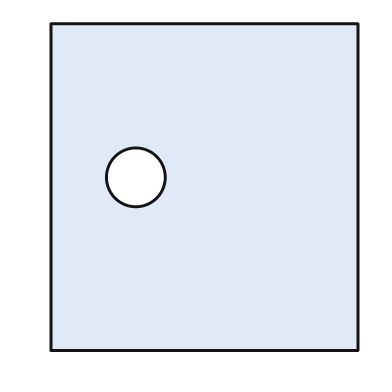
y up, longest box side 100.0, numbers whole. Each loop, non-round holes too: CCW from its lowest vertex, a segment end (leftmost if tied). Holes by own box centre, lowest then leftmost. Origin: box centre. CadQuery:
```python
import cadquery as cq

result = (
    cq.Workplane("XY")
    .moveTo(-47.0, -50.0)
    .lineTo(47.0, -50.0)
    .lineTo(47.0, 50.0)
    .lineTo(-47.0, 50.0)
    .close()
    .moveTo(-21.0, 3.0)
    .circle(9.0)
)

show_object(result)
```